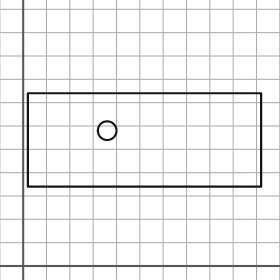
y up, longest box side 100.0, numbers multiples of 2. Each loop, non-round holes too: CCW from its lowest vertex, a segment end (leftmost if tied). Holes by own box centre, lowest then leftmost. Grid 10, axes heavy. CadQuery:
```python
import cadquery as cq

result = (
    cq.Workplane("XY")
    .moveTo(2.0, 34.0)
    .lineTo(102.0, 34.0)
    .lineTo(102.0, 74.0)
    .lineTo(2.0, 74.0)
    .close()
    .moveTo(36.0, 58.0)
    .circle(4.0)
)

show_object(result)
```